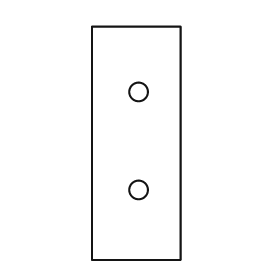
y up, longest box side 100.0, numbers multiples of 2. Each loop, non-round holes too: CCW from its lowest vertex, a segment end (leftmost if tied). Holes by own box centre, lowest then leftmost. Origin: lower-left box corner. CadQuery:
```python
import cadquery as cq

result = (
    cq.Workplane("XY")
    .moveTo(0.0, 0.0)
    .lineTo(38.0, 0.0)
    .lineTo(38.0, 100.0)
    .lineTo(0.0, 100.0)
    .close()
    .moveTo(20.0, 30.0)
    .circle(4.0)
    .moveTo(20.0, 72.0)
    .circle(4.0)
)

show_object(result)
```